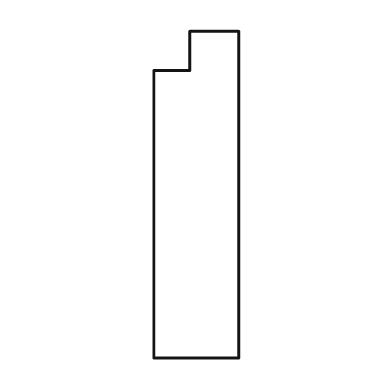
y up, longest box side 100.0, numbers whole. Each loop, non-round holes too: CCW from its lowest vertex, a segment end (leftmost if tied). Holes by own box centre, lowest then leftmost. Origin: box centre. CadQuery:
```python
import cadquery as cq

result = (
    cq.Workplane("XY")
    .moveTo(-13.0, -50.0)
    .lineTo(13.0, -50.0)
    .lineTo(13.0, 50.0)
    .lineTo(-2.0, 50.0)
    .lineTo(-2.0, 38.0)
    .lineTo(-13.0, 38.0)
    .close()
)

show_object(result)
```